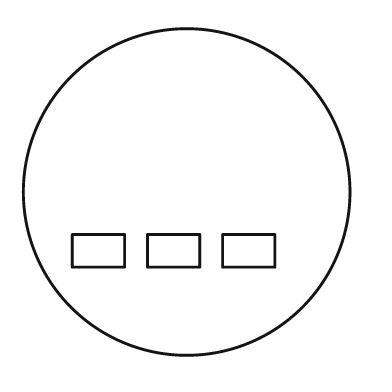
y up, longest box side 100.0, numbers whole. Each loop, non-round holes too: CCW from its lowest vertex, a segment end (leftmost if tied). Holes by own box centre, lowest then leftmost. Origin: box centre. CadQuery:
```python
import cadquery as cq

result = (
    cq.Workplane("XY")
    .moveTo(0.0, 0.0)
    .circle(50.0)
    .moveTo(-35.0, -23.0)
    .lineTo(-19.0, -23.0)
    .lineTo(-19.0, -13.0)
    .lineTo(-35.0, -13.0)
    .close()
    .moveTo(-12.0, -23.0)
    .lineTo(4.0, -23.0)
    .lineTo(4.0, -13.0)
    .lineTo(-12.0, -13.0)
    .close()
    .moveTo(11.0, -23.0)
    .lineTo(27.0, -23.0)
    .lineTo(27.0, -13.0)
    .lineTo(11.0, -13.0)
    .close()
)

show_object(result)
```